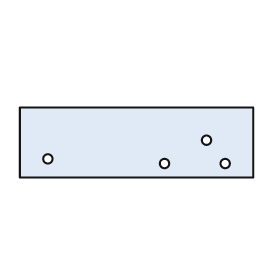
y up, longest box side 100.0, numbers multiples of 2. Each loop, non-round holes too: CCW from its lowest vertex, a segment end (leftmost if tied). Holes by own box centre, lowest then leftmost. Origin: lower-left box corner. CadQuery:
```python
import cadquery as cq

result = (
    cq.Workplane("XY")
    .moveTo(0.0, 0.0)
    .lineTo(100.0, 0.0)
    .lineTo(100.0, 30.0)
    .lineTo(0.0, 30.0)
    .close()
    .moveTo(62.0, 6.0)
    .circle(2.0)
    .moveTo(88.0, 6.0)
    .circle(2.0)
    .moveTo(12.0, 8.0)
    .circle(2.0)
    .moveTo(80.0, 16.0)
    .circle(2.0)
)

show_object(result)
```